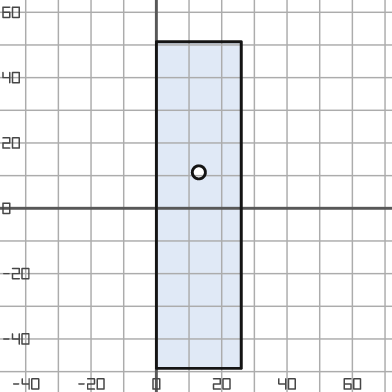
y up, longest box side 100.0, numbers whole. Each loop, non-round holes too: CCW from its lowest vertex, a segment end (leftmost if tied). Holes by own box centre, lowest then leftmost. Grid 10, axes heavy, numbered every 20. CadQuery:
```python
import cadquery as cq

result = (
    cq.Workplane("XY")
    .moveTo(0.0, -49.0)
    .lineTo(26.0, -49.0)
    .lineTo(26.0, 51.0)
    .lineTo(0.0, 51.0)
    .close()
    .moveTo(13.0, 11.0)
    .circle(2.0)
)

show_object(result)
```